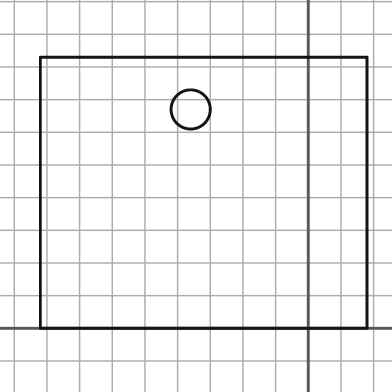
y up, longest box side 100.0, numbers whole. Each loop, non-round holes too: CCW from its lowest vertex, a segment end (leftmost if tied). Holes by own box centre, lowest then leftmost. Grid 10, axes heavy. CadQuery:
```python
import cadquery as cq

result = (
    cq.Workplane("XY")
    .moveTo(-82.0, 0.0)
    .lineTo(18.0, 0.0)
    .lineTo(18.0, 83.0)
    .lineTo(-82.0, 83.0)
    .close()
    .moveTo(-36.0, 67.0)
    .circle(6.0)
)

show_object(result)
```